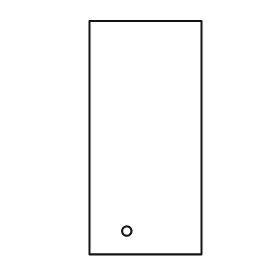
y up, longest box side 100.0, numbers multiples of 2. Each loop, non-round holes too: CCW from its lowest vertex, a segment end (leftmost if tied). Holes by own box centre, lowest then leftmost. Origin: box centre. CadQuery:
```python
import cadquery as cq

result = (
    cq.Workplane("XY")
    .moveTo(-24.0, -50.0)
    .lineTo(24.0, -50.0)
    .lineTo(24.0, 50.0)
    .lineTo(-24.0, 50.0)
    .close()
    .moveTo(-8.0, -40.0)
    .circle(2.0)
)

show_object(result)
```